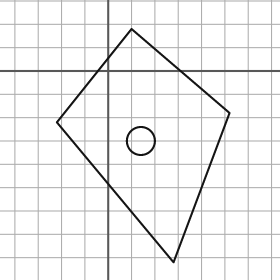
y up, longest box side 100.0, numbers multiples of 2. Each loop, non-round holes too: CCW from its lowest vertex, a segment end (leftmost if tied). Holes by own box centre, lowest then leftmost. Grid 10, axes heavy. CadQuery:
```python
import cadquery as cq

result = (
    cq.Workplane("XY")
    .moveTo(28.0, -82.0)
    .lineTo(52.0, -18.0)
    .lineTo(10.0, 18.0)
    .lineTo(-22.0, -22.0)
    .close()
    .moveTo(14.0, -30.0)
    .circle(6.0)
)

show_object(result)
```